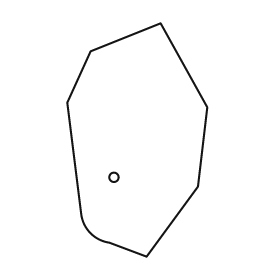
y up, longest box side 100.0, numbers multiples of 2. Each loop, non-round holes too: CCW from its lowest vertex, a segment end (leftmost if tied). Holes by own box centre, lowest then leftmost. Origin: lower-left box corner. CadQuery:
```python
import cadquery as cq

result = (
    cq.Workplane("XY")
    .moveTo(34.0, 0.0)
    .lineTo(56.0, 30.0)
    .lineTo(60.0, 64.0)
    .lineTo(40.0, 100.0)
    .lineTo(10.0, 88.0)
    .lineTo(0.0, 66.0)
    .lineTo(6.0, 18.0)
    .threePointArc((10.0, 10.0), (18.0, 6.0))
    .close()
    .moveTo(20.0, 34.0)
    .circle(2.0)
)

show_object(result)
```